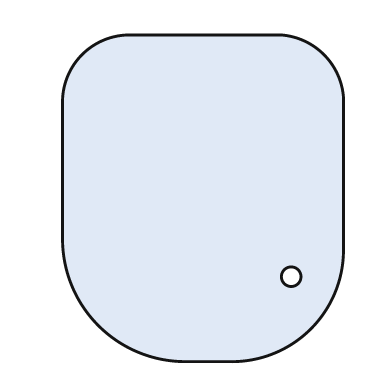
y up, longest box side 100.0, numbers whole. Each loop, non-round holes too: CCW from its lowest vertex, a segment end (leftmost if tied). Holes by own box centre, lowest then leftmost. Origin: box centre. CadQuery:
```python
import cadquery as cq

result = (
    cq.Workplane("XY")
    .moveTo(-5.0, -50.0)
    .lineTo(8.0, -50.0)
    .threePointArc((33.0, -40.0), (43.0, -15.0))
    .lineTo(43.0, 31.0)
    .threePointArc((37.0, 44.0), (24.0, 50.0))
    .lineTo(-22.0, 50.0)
    .threePointArc((-37.0, 44.0), (-43.0, 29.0))
    .lineTo(-43.0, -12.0)
    .threePointArc((-32.0, -39.0), (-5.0, -50.0))
    .close()
    .moveTo(27.0, -24.0)
    .circle(3.0)
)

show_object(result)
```